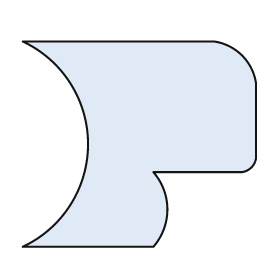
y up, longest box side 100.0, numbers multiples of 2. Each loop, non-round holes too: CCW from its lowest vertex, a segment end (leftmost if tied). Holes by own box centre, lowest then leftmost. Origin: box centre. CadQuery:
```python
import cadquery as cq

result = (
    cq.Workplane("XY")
    .moveTo(-50.0, -44.0)
    .lineTo(6.0, -44.0)
    .threePointArc((12.0, -28.0), (6.0, -12.0))
    .lineTo(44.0, -12.0)
    .threePointArc((48.0, -10.0), (50.0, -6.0))
    .lineTo(50.0, 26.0)
    .threePointArc((44.0, 38.0), (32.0, 44.0))
    .lineTo(-50.0, 44.0)
    .threePointArc((-22.0, 0.0), (-50.0, -44.0))
    .close()
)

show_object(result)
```